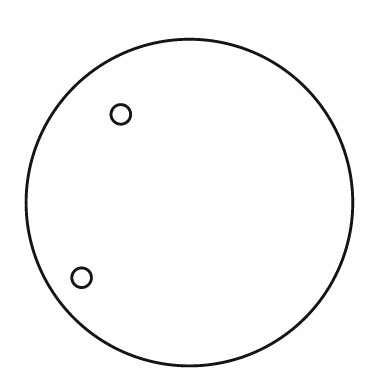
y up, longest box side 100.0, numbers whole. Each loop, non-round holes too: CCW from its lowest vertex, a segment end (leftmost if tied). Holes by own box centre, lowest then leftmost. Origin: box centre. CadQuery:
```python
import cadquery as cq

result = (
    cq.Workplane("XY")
    .moveTo(0.0, 0.0)
    .circle(50.0)
    .moveTo(-33.0, -23.0)
    .circle(3.0)
    .moveTo(-21.0, 27.0)
    .circle(3.0)
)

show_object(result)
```